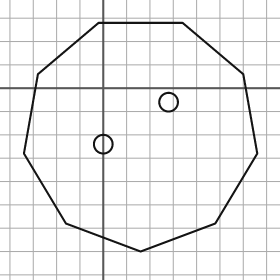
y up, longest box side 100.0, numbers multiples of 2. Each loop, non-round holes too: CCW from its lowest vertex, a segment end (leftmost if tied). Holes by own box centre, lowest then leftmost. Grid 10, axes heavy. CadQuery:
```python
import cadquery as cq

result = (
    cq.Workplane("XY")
    .moveTo(16.0, -70.0)
    .lineTo(48.0, -58.0)
    .lineTo(66.0, -28.0)
    .lineTo(60.0, 6.0)
    .lineTo(34.0, 28.0)
    .lineTo(-2.0, 28.0)
    .lineTo(-28.0, 6.0)
    .lineTo(-34.0, -28.0)
    .lineTo(-16.0, -58.0)
    .close()
    .moveTo(0.0, -24.0)
    .circle(4.0)
    .moveTo(28.0, -6.0)
    .circle(4.0)
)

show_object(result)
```